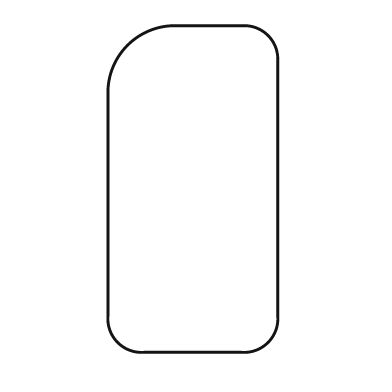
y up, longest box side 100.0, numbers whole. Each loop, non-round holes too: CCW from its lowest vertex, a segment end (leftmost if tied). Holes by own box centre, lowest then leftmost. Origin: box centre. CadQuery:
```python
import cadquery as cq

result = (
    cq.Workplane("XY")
    .moveTo(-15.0, -50.0)
    .lineTo(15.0, -50.0)
    .threePointArc((23.0, -47.0), (26.0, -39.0))
    .lineTo(26.0, 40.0)
    .threePointArc((23.0, 47.0), (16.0, 50.0))
    .lineTo(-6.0, 50.0)
    .threePointArc((-20.0, 44.0), (-26.0, 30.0))
    .lineTo(-26.0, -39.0)
    .threePointArc((-23.0, -47.0), (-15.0, -50.0))
    .close()
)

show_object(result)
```